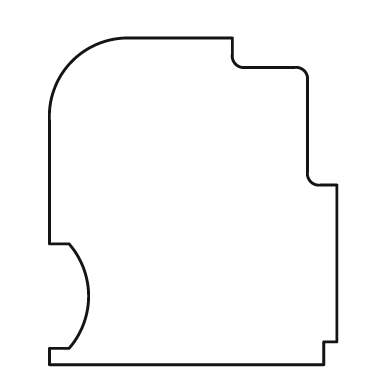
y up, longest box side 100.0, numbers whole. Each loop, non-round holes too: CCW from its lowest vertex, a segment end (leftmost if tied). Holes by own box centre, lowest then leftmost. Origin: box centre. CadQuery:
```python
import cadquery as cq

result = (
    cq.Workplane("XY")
    .moveTo(-44.0, -50.0)
    .lineTo(40.0, -50.0)
    .lineTo(40.0, -43.0)
    .lineTo(44.0, -43.0)
    .lineTo(44.0, 5.0)
    .lineTo(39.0, 5.0)
    .threePointArc((36.0, 6.0), (35.0, 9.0))
    .lineTo(35.0, 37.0)
    .threePointArc((34.0, 40.0), (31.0, 41.0))
    .lineTo(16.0, 41.0)
    .threePointArc((13.0, 42.0), (12.0, 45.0))
    .lineTo(12.0, 50.0)
    .lineTo(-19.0, 50.0)
    .threePointArc((-37.0, 43.0), (-44.0, 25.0))
    .lineTo(-44.0, -13.0)
    .lineTo(-38.0, -13.0)
    .threePointArc((-32.0, -29.0), (-38.0, -45.0))
    .lineTo(-44.0, -45.0)
    .close()
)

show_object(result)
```